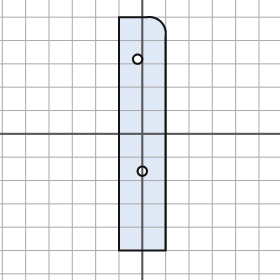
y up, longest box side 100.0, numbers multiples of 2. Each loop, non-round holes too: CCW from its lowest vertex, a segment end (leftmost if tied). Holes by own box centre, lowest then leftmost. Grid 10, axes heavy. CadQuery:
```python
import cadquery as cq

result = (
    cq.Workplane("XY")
    .moveTo(-10.0, -50.0)
    .lineTo(10.0, -50.0)
    .lineTo(10.0, 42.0)
    .threePointArc((8.0, 48.0), (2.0, 50.0))
    .lineTo(-10.0, 50.0)
    .close()
    .moveTo(0.0, -16.0)
    .circle(2.0)
    .moveTo(-2.0, 32.0)
    .circle(2.0)
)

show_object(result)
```